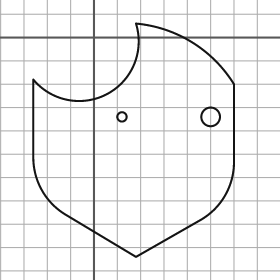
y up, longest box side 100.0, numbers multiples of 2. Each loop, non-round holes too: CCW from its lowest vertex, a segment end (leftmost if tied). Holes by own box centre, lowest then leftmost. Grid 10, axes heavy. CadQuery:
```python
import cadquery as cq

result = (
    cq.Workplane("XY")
    .moveTo(18.0, -94.0)
    .lineTo(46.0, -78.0)
    .threePointArc((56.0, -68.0), (60.0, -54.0))
    .lineTo(60.0, -20.0)
    .threePointArc((42.0, -2.0), (18.0, 6.0))
    .threePointArc((6.0, -24.0), (-26.0, -18.0))
    .lineTo(-26.0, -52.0)
    .threePointArc((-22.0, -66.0), (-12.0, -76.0))
    .close()
    .moveTo(12.0, -34.0)
    .circle(2.0)
    .moveTo(50.0, -34.0)
    .circle(4.0)
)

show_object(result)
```